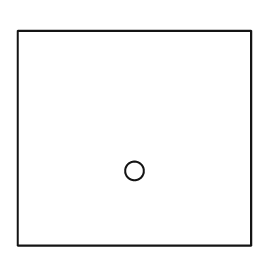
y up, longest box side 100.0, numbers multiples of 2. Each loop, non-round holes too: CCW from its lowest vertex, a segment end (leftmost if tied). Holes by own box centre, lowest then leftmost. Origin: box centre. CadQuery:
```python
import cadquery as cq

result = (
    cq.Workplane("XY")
    .moveTo(-50.0, -46.0)
    .lineTo(50.0, -46.0)
    .lineTo(50.0, 46.0)
    .lineTo(-50.0, 46.0)
    .close()
    .moveTo(0.0, -14.0)
    .circle(4.0)
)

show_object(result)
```